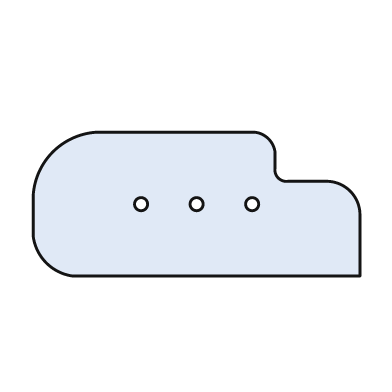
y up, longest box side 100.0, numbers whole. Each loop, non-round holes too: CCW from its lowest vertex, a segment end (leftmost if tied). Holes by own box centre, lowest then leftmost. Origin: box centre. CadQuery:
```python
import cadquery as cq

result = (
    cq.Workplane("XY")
    .moveTo(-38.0, -22.0)
    .lineTo(50.0, -22.0)
    .lineTo(50.0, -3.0)
    .threePointArc((47.0, 4.0), (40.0, 7.0))
    .lineTo(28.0, 7.0)
    .threePointArc((25.0, 8.0), (24.0, 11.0))
    .lineTo(24.0, 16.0)
    .threePointArc((22.0, 20.0), (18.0, 22.0))
    .lineTo(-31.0, 22.0)
    .threePointArc((-44.0, 16.0), (-50.0, 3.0))
    .lineTo(-50.0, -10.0)
    .threePointArc((-46.0, -18.0), (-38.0, -22.0))
    .close()
    .moveTo(-17.0, 0.0)
    .circle(2.0)
    .moveTo(0.0, 0.0)
    .circle(2.0)
    .moveTo(17.0, 0.0)
    .circle(2.0)
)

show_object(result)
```